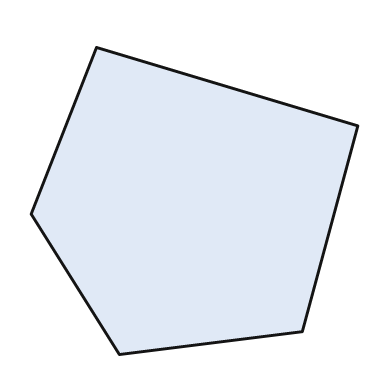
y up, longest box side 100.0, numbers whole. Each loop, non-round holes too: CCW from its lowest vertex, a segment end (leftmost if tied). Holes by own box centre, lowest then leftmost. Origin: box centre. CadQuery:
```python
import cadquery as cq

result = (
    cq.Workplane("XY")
    .moveTo(-23.0, -47.0)
    .lineTo(33.0, -40.0)
    .lineTo(50.0, 23.0)
    .lineTo(-30.0, 47.0)
    .lineTo(-50.0, -4.0)
    .close()
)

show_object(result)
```